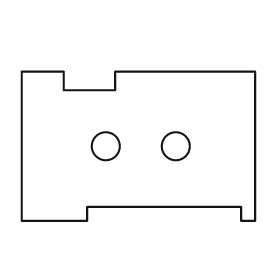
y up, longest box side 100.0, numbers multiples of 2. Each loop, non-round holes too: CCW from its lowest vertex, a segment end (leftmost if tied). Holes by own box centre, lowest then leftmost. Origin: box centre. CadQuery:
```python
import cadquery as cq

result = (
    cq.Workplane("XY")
    .moveTo(-50.0, -32.0)
    .lineTo(-22.0, -32.0)
    .lineTo(-22.0, -26.0)
    .lineTo(44.0, -26.0)
    .lineTo(44.0, -32.0)
    .lineTo(50.0, -32.0)
    .lineTo(50.0, 32.0)
    .lineTo(-10.0, 32.0)
    .lineTo(-10.0, 24.0)
    .lineTo(-32.0, 24.0)
    .lineTo(-32.0, 32.0)
    .lineTo(-50.0, 32.0)
    .close()
    .moveTo(-14.0, 0.0)
    .circle(6.0)
    .moveTo(16.0, 0.0)
    .circle(6.0)
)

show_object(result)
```